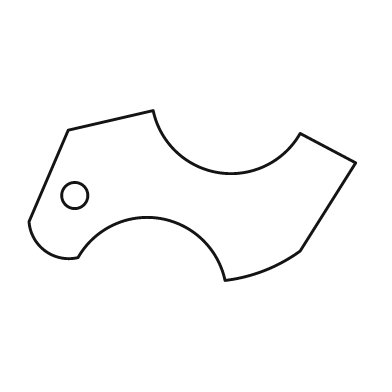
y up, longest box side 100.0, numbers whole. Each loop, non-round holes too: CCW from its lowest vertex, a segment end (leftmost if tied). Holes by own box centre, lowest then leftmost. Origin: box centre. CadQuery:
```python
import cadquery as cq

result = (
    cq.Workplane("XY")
    .moveTo(10.0, -26.0)
    .threePointArc((22.0, -23.0), (33.0, -17.0))
    .lineTo(50.0, 10.0)
    .lineTo(33.0, 19.0)
    .threePointArc((8.0, 7.0), (-12.0, 26.0))
    .lineTo(-38.0, 20.0)
    .lineTo(-50.0, -8.0)
    .threePointArc((-45.0, -17.0), (-35.0, -19.0))
    .threePointArc((-10.0, -7.0), (10.0, -26.0))
    .close()
    .moveTo(-36.0, 0.0)
    .circle(4.0)
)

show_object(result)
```